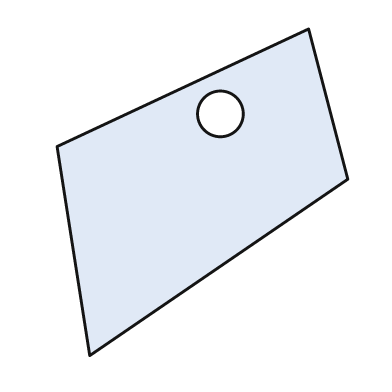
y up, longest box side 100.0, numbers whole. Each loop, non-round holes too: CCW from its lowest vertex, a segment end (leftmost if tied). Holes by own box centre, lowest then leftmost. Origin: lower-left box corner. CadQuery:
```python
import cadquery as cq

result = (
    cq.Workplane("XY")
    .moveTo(10.0, 0.0)
    .lineTo(89.0, 54.0)
    .lineTo(77.0, 100.0)
    .lineTo(0.0, 64.0)
    .close()
    .moveTo(50.0, 74.0)
    .circle(7.0)
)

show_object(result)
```